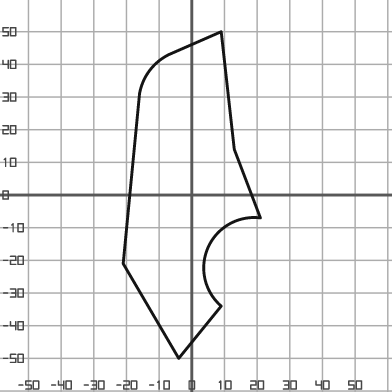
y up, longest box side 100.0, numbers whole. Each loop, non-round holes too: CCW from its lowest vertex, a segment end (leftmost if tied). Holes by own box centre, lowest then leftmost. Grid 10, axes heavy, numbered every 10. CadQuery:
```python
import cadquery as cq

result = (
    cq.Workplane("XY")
    .moveTo(-4.0, -50.0)
    .lineTo(9.0, -34.0)
    .threePointArc((5.0, -16.0), (21.0, -7.0))
    .lineTo(13.0, 14.0)
    .lineTo(9.0, 50.0)
    .lineTo(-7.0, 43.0)
    .threePointArc((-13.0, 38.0), (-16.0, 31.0))
    .lineTo(-21.0, -21.0)
    .close()
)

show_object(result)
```